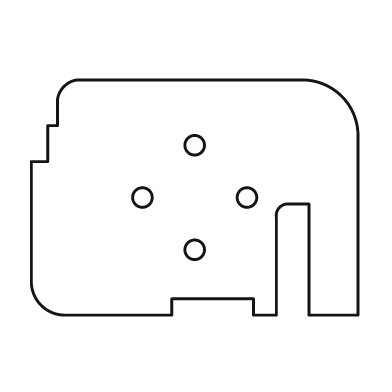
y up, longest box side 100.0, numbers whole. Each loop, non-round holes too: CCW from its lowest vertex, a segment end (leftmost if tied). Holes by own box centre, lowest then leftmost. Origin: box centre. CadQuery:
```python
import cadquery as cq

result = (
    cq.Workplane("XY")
    .moveTo(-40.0, -36.0)
    .lineTo(-7.0, -36.0)
    .lineTo(-7.0, -31.0)
    .lineTo(18.0, -31.0)
    .lineTo(18.0, -36.0)
    .lineTo(25.0, -36.0)
    .lineTo(25.0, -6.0)
    .threePointArc((26.0, -3.0), (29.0, -2.0))
    .lineTo(35.0, -2.0)
    .lineTo(35.0, -36.0)
    .lineTo(50.0, -36.0)
    .lineTo(50.0, 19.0)
    .threePointArc((45.0, 31.0), (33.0, 36.0))
    .lineTo(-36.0, 36.0)
    .threePointArc((-40.0, 34.0), (-42.0, 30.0))
    .lineTo(-42.0, 22.0)
    .lineTo(-45.0, 22.0)
    .lineTo(-45.0, 11.0)
    .lineTo(-50.0, 11.0)
    .lineTo(-50.0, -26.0)
    .threePointArc((-47.0, -33.0), (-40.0, -36.0))
    .close()
    .moveTo(0.0, -16.0)
    .circle(3.0)
    .moveTo(-16.0, 0.0)
    .circle(3.0)
    .moveTo(16.0, 0.0)
    .circle(3.0)
    .moveTo(0.0, 16.0)
    .circle(3.0)
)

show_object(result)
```